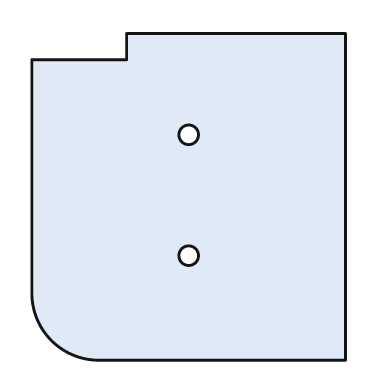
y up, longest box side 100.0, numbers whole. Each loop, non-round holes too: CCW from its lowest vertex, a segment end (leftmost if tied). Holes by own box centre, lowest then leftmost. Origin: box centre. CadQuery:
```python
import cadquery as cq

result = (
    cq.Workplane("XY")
    .moveTo(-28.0, -50.0)
    .lineTo(48.0, -50.0)
    .lineTo(48.0, 50.0)
    .lineTo(-19.0, 50.0)
    .lineTo(-19.0, 42.0)
    .lineTo(-48.0, 42.0)
    .lineTo(-48.0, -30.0)
    .threePointArc((-42.0, -44.0), (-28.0, -50.0))
    .close()
    .moveTo(0.0, -18.0)
    .circle(3.0)
    .moveTo(0.0, 19.0)
    .circle(3.0)
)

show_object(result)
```